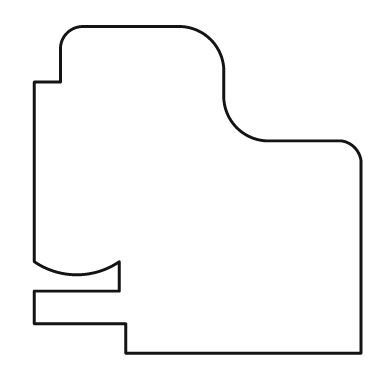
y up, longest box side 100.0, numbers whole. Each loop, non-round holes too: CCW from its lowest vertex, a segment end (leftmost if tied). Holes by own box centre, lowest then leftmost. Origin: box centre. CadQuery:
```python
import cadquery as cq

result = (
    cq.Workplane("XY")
    .moveTo(-22.0, -50.0)
    .lineTo(50.0, -50.0)
    .lineTo(50.0, 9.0)
    .threePointArc((48.0, 13.0), (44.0, 15.0))
    .lineTo(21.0, 15.0)
    .threePointArc((12.0, 19.0), (8.0, 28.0))
    .lineTo(8.0, 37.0)
    .threePointArc((4.0, 46.0), (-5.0, 50.0))
    .lineTo(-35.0, 50.0)
    .threePointArc((-40.0, 48.0), (-42.0, 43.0))
    .lineTo(-42.0, 33.0)
    .lineTo(-50.0, 33.0)
    .lineTo(-50.0, -22.0)
    .threePointArc((-37.0, -26.0), (-24.0, -22.0))
    .lineTo(-24.0, -31.0)
    .lineTo(-50.0, -31.0)
    .lineTo(-50.0, -41.0)
    .lineTo(-22.0, -41.0)
    .close()
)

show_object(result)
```